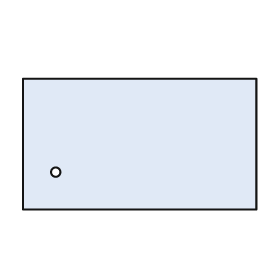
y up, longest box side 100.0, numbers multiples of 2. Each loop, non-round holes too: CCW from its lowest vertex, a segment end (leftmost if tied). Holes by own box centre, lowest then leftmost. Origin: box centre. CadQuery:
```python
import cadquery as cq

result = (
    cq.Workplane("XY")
    .moveTo(-50.0, -28.0)
    .lineTo(50.0, -28.0)
    .lineTo(50.0, 28.0)
    .lineTo(-50.0, 28.0)
    .close()
    .moveTo(-36.0, -12.0)
    .circle(2.0)
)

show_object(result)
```